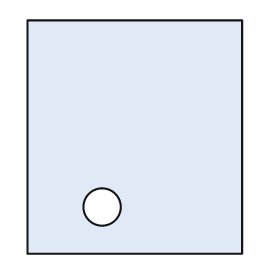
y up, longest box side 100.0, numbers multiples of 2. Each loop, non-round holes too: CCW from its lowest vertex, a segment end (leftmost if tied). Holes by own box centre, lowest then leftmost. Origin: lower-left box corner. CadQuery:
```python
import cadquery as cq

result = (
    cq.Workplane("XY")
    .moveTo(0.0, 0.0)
    .lineTo(92.0, 0.0)
    .lineTo(92.0, 100.0)
    .lineTo(0.0, 100.0)
    .close()
    .moveTo(32.0, 20.0)
    .circle(8.0)
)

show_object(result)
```